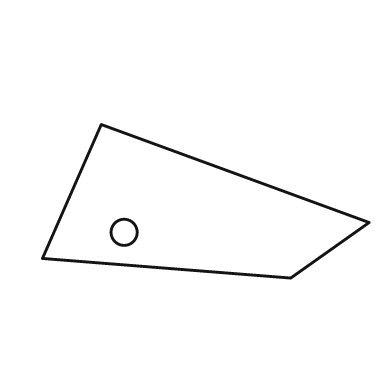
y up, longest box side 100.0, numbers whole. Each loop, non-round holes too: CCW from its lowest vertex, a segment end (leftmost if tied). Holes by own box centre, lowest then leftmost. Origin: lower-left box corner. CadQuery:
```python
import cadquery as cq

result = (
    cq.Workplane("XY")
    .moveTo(76.0, 0.0)
    .lineTo(100.0, 17.0)
    .lineTo(18.0, 47.0)
    .lineTo(0.0, 6.0)
    .close()
    .moveTo(25.0, 14.0)
    .circle(4.0)
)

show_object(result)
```